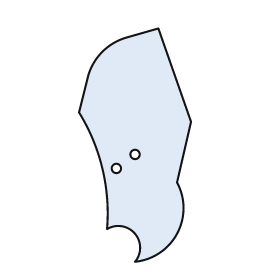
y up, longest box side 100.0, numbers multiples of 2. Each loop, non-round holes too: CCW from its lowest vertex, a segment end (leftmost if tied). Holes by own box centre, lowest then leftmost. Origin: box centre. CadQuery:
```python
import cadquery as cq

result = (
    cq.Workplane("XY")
    .moveTo(0.0, -50.0)
    .threePointArc((18.0, -38.0), (18.0, -16.0))
    .lineTo(24.0, 10.0)
    .lineTo(10.0, 50.0)
    .lineTo(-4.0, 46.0)
    .threePointArc((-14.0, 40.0), (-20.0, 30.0))
    .lineTo(-24.0, 14.0)
    .threePointArc((-14.0, -10.0), (-12.0, -36.0))
    .threePointArc((0.0, -38.0), (0.0, -50.0))
    .close()
    .moveTo(-8.0, -10.0)
    .circle(2.0)
    .moveTo(0.0, -4.0)
    .circle(2.0)
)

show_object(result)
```